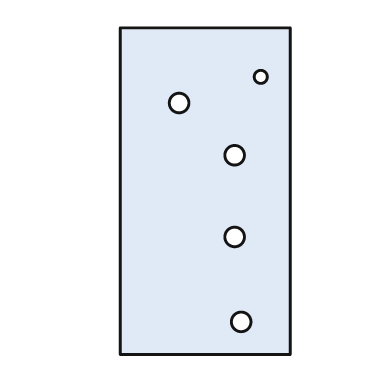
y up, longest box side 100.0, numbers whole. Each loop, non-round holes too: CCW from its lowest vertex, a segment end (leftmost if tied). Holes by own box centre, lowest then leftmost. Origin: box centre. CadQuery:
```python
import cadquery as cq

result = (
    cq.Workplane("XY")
    .moveTo(-26.0, -50.0)
    .lineTo(26.0, -50.0)
    .lineTo(26.0, 50.0)
    .lineTo(-26.0, 50.0)
    .close()
    .moveTo(11.0, -40.0)
    .circle(3.0)
    .moveTo(9.0, -14.0)
    .circle(3.0)
    .moveTo(9.0, 11.0)
    .circle(3.0)
    .moveTo(-8.0, 27.0)
    .circle(3.0)
    .moveTo(17.0, 35.0)
    .circle(2.0)
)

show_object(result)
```